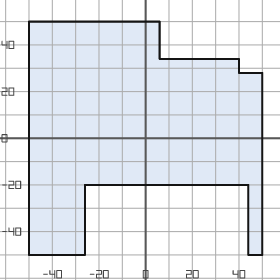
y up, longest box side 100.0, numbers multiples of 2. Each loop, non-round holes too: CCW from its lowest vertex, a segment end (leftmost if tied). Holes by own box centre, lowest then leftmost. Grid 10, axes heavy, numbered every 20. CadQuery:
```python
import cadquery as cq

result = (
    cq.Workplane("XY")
    .moveTo(-50.0, -50.0)
    .lineTo(-26.0, -50.0)
    .lineTo(-26.0, -20.0)
    .lineTo(44.0, -20.0)
    .lineTo(44.0, -50.0)
    .lineTo(50.0, -50.0)
    .lineTo(50.0, 28.0)
    .lineTo(40.0, 28.0)
    .lineTo(40.0, 34.0)
    .lineTo(6.0, 34.0)
    .lineTo(6.0, 50.0)
    .lineTo(-50.0, 50.0)
    .close()
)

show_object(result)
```